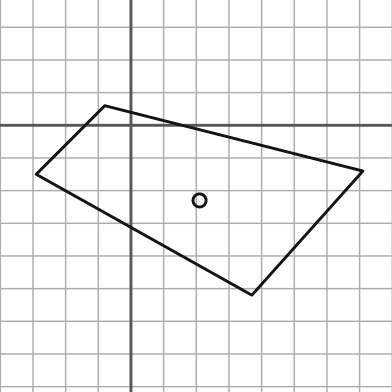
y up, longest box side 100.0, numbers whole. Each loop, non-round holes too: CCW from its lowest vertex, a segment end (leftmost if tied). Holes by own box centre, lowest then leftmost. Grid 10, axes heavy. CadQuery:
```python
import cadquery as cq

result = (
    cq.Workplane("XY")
    .moveTo(37.0, -52.0)
    .lineTo(71.0, -14.0)
    .lineTo(-8.0, 6.0)
    .lineTo(-29.0, -15.0)
    .close()
    .moveTo(21.0, -23.0)
    .circle(2.0)
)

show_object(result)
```